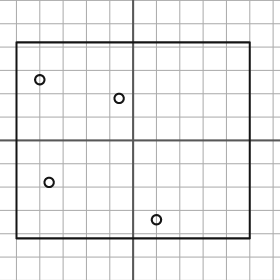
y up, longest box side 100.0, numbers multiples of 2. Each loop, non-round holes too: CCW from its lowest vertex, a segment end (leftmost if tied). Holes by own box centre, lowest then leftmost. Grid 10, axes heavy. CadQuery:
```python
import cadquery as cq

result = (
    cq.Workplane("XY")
    .moveTo(-50.0, -42.0)
    .lineTo(50.0, -42.0)
    .lineTo(50.0, 42.0)
    .lineTo(-50.0, 42.0)
    .close()
    .moveTo(10.0, -34.0)
    .circle(2.0)
    .moveTo(-36.0, -18.0)
    .circle(2.0)
    .moveTo(-6.0, 18.0)
    .circle(2.0)
    .moveTo(-40.0, 26.0)
    .circle(2.0)
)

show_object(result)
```